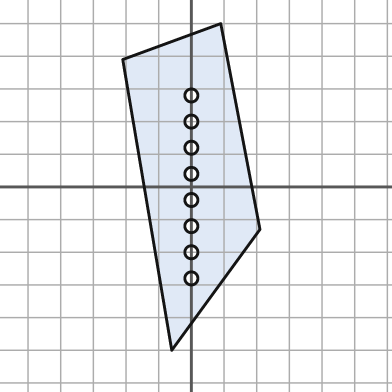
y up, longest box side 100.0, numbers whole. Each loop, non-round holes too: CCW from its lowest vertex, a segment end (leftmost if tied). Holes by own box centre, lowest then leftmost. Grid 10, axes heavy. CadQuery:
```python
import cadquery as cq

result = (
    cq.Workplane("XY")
    .moveTo(-6.0, -50.0)
    .lineTo(21.0, -13.0)
    .lineTo(9.0, 50.0)
    .lineTo(-21.0, 39.0)
    .close()
    .moveTo(0.0, -28.0)
    .circle(2.0)
    .moveTo(0.0, -20.0)
    .circle(2.0)
    .moveTo(0.0, -12.0)
    .circle(2.0)
    .moveTo(0.0, -4.0)
    .circle(2.0)
    .moveTo(0.0, 4.0)
    .circle(2.0)
    .moveTo(0.0, 12.0)
    .circle(2.0)
    .moveTo(0.0, 20.0)
    .circle(2.0)
    .moveTo(0.0, 28.0)
    .circle(2.0)
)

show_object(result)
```